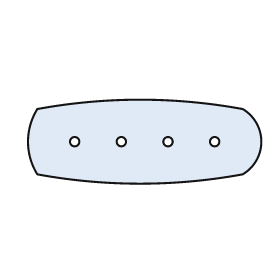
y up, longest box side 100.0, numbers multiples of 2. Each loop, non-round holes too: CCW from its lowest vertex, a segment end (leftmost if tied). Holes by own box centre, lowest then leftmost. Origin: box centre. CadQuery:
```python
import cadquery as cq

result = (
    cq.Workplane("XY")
    .moveTo(-46.0, -14.0)
    .threePointArc((-2.0, -18.0), (42.0, -14.0))
    .threePointArc((50.0, 0.0), (42.0, 14.0))
    .threePointArc((-2.0, 18.0), (-46.0, 14.0))
    .threePointArc((-50.0, 0.0), (-46.0, -14.0))
    .close()
    .moveTo(-30.0, 0.0)
    .circle(2.0)
    .moveTo(-10.0, 0.0)
    .circle(2.0)
    .moveTo(10.0, 0.0)
    .circle(2.0)
    .moveTo(30.0, 0.0)
    .circle(2.0)
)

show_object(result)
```